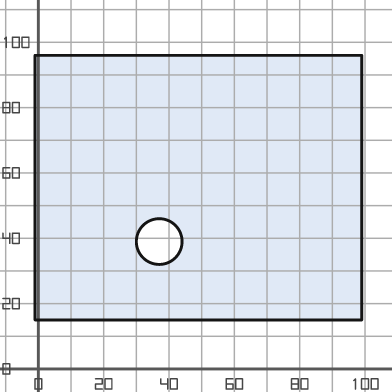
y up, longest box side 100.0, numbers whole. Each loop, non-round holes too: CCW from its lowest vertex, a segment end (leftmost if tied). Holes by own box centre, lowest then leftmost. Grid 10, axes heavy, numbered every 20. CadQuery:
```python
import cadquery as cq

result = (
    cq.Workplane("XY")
    .moveTo(-1.0, 15.0)
    .lineTo(99.0, 15.0)
    .lineTo(99.0, 96.0)
    .lineTo(-1.0, 96.0)
    .close()
    .moveTo(37.0, 39.0)
    .circle(7.0)
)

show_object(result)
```